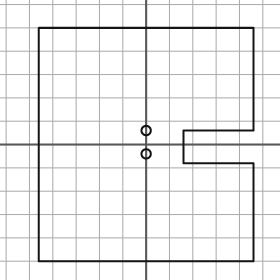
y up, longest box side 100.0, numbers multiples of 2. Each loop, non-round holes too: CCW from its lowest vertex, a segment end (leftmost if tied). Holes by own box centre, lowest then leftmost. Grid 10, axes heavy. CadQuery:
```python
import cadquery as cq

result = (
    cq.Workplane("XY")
    .moveTo(-46.0, -50.0)
    .lineTo(46.0, -50.0)
    .lineTo(46.0, -8.0)
    .lineTo(16.0, -8.0)
    .lineTo(16.0, 6.0)
    .lineTo(46.0, 6.0)
    .lineTo(46.0, 50.0)
    .lineTo(-46.0, 50.0)
    .close()
    .moveTo(0.0, -4.0)
    .circle(2.0)
    .moveTo(0.0, 6.0)
    .circle(2.0)
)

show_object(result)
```